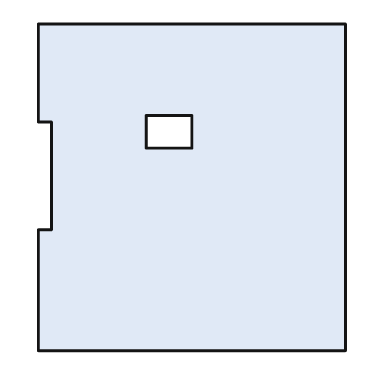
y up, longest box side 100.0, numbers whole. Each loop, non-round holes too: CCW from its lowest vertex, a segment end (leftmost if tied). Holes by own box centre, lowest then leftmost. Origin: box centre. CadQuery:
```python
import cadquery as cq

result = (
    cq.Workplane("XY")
    .moveTo(-47.0, -50.0)
    .lineTo(47.0, -50.0)
    .lineTo(47.0, 50.0)
    .lineTo(-47.0, 50.0)
    .lineTo(-47.0, 20.0)
    .lineTo(-43.0, 20.0)
    .lineTo(-43.0, -13.0)
    .lineTo(-47.0, -13.0)
    .close()
    .moveTo(-14.0, 12.0)
    .lineTo(0.0, 12.0)
    .lineTo(0.0, 22.0)
    .lineTo(-14.0, 22.0)
    .close()
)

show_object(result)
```